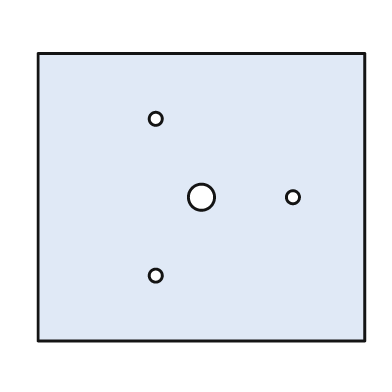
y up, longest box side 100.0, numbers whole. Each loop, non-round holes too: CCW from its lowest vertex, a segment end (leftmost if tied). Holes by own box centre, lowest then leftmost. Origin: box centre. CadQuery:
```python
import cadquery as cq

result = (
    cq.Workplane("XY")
    .moveTo(-50.0, -44.0)
    .lineTo(50.0, -44.0)
    .lineTo(50.0, 44.0)
    .lineTo(-50.0, 44.0)
    .close()
    .moveTo(-14.0, -24.0)
    .circle(2.0)
    .moveTo(0.0, 0.0)
    .circle(4.0)
    .moveTo(28.0, 0.0)
    .circle(2.0)
    .moveTo(-14.0, 24.0)
    .circle(2.0)
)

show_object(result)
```